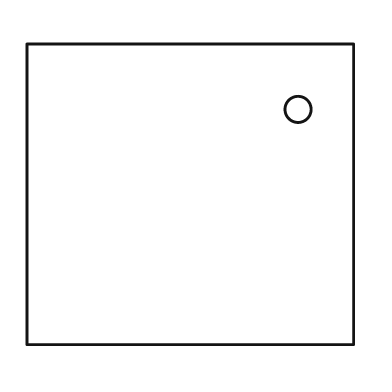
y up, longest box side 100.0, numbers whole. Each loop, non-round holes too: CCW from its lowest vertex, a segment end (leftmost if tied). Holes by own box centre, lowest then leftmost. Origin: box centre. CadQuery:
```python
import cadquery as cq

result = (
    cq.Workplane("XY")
    .moveTo(-50.0, -46.0)
    .lineTo(50.0, -46.0)
    .lineTo(50.0, 46.0)
    .lineTo(-50.0, 46.0)
    .close()
    .moveTo(33.0, 26.0)
    .circle(4.0)
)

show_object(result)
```